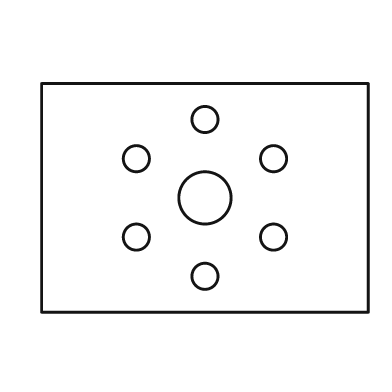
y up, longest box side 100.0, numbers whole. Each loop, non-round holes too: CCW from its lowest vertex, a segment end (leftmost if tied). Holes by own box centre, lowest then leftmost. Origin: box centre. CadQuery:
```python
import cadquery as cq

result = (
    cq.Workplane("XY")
    .moveTo(-50.0, -35.0)
    .lineTo(50.0, -35.0)
    .lineTo(50.0, 35.0)
    .lineTo(-50.0, 35.0)
    .close()
    .moveTo(0.0, -24.0)
    .circle(4.0)
    .moveTo(-21.0, -12.0)
    .circle(4.0)
    .moveTo(21.0, -12.0)
    .circle(4.0)
    .moveTo(0.0, 0.0)
    .circle(8.0)
    .moveTo(-21.0, 12.0)
    .circle(4.0)
    .moveTo(21.0, 12.0)
    .circle(4.0)
    .moveTo(0.0, 24.0)
    .circle(4.0)
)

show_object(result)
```